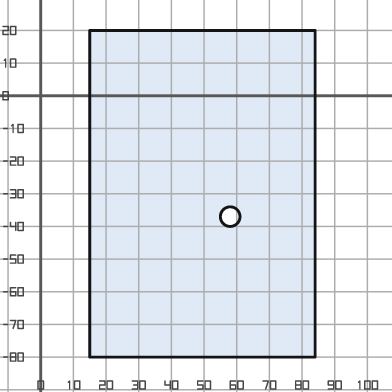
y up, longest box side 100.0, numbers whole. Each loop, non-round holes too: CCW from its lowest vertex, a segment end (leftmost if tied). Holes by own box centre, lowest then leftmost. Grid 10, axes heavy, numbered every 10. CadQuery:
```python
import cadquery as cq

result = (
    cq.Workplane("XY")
    .moveTo(15.0, -80.0)
    .lineTo(84.0, -80.0)
    .lineTo(84.0, 20.0)
    .lineTo(15.0, 20.0)
    .close()
    .moveTo(58.0, -37.0)
    .circle(3.0)
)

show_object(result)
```